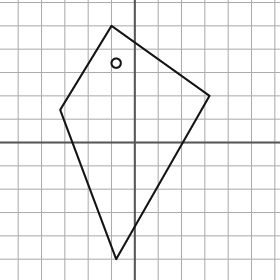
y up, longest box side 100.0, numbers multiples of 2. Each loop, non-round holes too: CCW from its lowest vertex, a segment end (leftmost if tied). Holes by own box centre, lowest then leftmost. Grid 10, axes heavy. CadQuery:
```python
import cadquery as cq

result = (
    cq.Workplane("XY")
    .moveTo(-8.0, -50.0)
    .lineTo(32.0, 20.0)
    .lineTo(-10.0, 50.0)
    .lineTo(-32.0, 14.0)
    .close()
    .moveTo(-8.0, 34.0)
    .circle(2.0)
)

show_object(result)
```